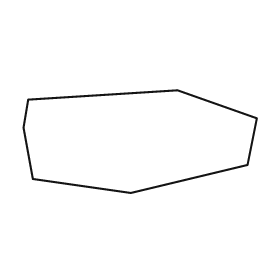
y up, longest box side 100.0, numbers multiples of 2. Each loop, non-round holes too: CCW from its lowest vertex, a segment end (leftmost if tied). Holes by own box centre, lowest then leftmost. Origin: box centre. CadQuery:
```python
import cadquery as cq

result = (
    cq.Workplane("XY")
    .moveTo(-4.0, -22.0)
    .lineTo(46.0, -10.0)
    .lineTo(50.0, 10.0)
    .lineTo(16.0, 22.0)
    .lineTo(-48.0, 18.0)
    .lineTo(-50.0, 6.0)
    .lineTo(-46.0, -16.0)
    .close()
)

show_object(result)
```